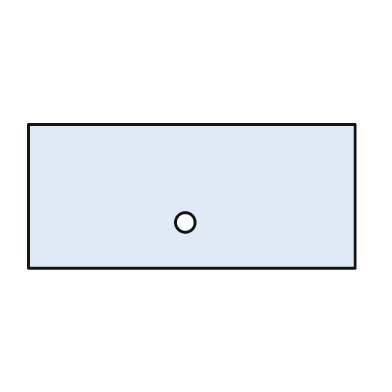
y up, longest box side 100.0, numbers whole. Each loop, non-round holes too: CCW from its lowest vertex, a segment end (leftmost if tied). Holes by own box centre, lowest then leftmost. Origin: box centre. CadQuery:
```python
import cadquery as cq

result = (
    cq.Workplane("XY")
    .moveTo(-50.0, -22.0)
    .lineTo(50.0, -22.0)
    .lineTo(50.0, 22.0)
    .lineTo(-50.0, 22.0)
    .close()
    .moveTo(-2.0, -8.0)
    .circle(3.0)
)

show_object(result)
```